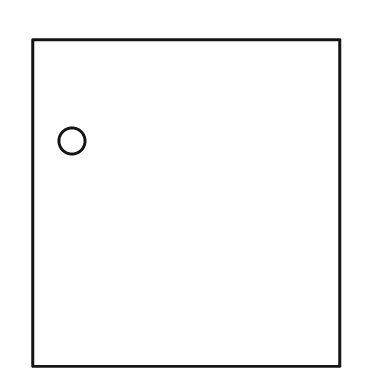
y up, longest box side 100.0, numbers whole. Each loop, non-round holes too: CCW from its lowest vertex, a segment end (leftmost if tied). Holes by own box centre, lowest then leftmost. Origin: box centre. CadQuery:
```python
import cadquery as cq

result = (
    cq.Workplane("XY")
    .moveTo(-47.0, -50.0)
    .lineTo(47.0, -50.0)
    .lineTo(47.0, 50.0)
    .lineTo(-47.0, 50.0)
    .close()
    .moveTo(-35.0, 19.0)
    .circle(4.0)
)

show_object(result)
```